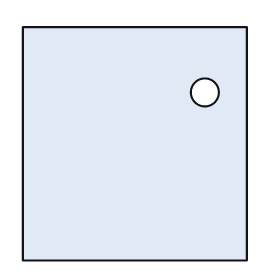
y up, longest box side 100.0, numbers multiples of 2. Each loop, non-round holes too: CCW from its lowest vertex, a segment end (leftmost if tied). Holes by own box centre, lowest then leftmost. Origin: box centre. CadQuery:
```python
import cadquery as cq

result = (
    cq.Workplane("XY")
    .moveTo(-48.0, -50.0)
    .lineTo(48.0, -50.0)
    .lineTo(48.0, 50.0)
    .lineTo(-48.0, 50.0)
    .close()
    .moveTo(30.0, 22.0)
    .circle(6.0)
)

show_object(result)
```